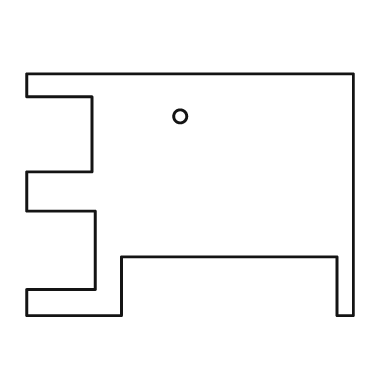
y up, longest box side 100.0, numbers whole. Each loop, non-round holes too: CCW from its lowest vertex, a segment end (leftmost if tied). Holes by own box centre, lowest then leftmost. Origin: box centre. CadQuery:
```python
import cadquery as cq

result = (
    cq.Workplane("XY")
    .moveTo(-50.0, -37.0)
    .lineTo(-21.0, -37.0)
    .lineTo(-21.0, -19.0)
    .lineTo(45.0, -19.0)
    .lineTo(45.0, -37.0)
    .lineTo(50.0, -37.0)
    .lineTo(50.0, 37.0)
    .lineTo(-50.0, 37.0)
    .lineTo(-50.0, 30.0)
    .lineTo(-30.0, 30.0)
    .lineTo(-30.0, 7.0)
    .lineTo(-50.0, 7.0)
    .lineTo(-50.0, -5.0)
    .lineTo(-29.0, -5.0)
    .lineTo(-29.0, -29.0)
    .lineTo(-50.0, -29.0)
    .close()
    .moveTo(-3.0, 24.0)
    .circle(2.0)
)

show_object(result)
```